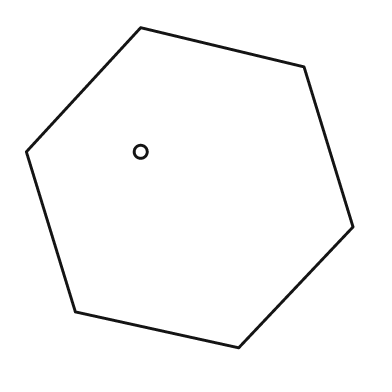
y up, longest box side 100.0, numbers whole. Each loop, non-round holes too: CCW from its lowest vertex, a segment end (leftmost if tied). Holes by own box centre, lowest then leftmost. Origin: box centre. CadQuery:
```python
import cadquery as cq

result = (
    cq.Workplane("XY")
    .moveTo(15.0, -49.0)
    .lineTo(50.0, -12.0)
    .lineTo(35.0, 37.0)
    .lineTo(-15.0, 49.0)
    .lineTo(-50.0, 11.0)
    .lineTo(-35.0, -38.0)
    .close()
    .moveTo(-15.0, 11.0)
    .circle(2.0)
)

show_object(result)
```